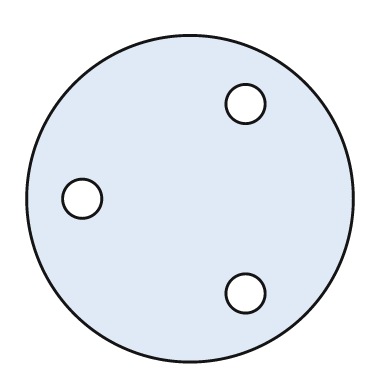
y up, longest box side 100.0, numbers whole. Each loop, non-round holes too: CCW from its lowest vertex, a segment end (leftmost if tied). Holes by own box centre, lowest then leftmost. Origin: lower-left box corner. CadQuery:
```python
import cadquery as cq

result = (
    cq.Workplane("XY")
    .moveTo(50.0, 50.0)
    .circle(50.0)
    .moveTo(67.0, 21.0)
    .circle(6.0)
    .moveTo(17.0, 50.0)
    .circle(6.0)
    .moveTo(67.0, 79.0)
    .circle(6.0)
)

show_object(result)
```